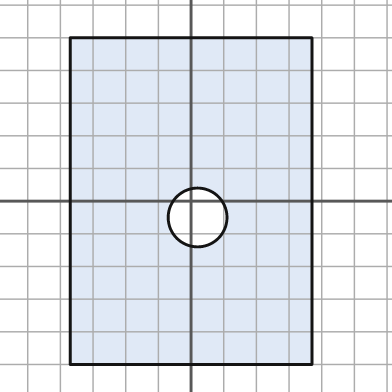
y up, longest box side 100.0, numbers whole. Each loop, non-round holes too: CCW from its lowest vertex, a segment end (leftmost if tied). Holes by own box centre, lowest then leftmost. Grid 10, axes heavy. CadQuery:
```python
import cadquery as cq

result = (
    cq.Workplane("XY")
    .moveTo(-37.0, -50.0)
    .lineTo(37.0, -50.0)
    .lineTo(37.0, 50.0)
    .lineTo(-37.0, 50.0)
    .close()
    .moveTo(2.0, -5.0)
    .circle(9.0)
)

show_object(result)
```